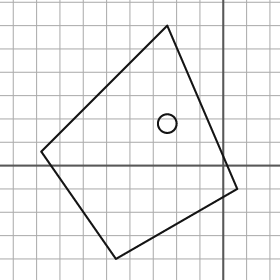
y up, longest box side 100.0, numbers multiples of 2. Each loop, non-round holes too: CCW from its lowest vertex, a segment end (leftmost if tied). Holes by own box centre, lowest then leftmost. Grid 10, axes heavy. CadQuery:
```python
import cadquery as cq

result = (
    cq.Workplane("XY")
    .moveTo(-46.0, -40.0)
    .lineTo(6.0, -10.0)
    .lineTo(-24.0, 60.0)
    .lineTo(-78.0, 6.0)
    .close()
    .moveTo(-24.0, 18.0)
    .circle(4.0)
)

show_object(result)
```